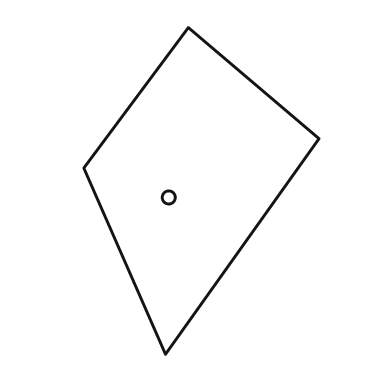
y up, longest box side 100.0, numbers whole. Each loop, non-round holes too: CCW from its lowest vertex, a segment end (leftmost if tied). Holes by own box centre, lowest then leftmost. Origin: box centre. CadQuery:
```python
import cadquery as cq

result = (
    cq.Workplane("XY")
    .moveTo(-11.0, -50.0)
    .lineTo(36.0, 16.0)
    .lineTo(-4.0, 50.0)
    .lineTo(-36.0, 7.0)
    .close()
    .moveTo(-10.0, -2.0)
    .circle(2.0)
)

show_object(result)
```